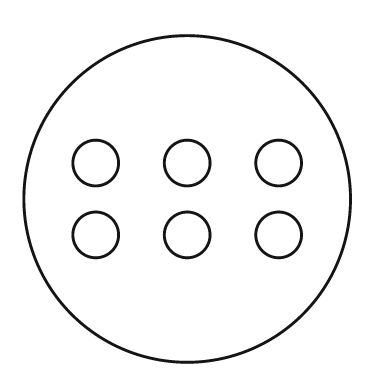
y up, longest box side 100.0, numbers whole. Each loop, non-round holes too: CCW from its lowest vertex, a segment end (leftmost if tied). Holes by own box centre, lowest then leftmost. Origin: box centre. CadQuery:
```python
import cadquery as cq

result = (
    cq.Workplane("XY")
    .moveTo(0.0, 0.0)
    .circle(50.0)
    .moveTo(-28.0, -11.0)
    .circle(7.0)
    .moveTo(0.0, -11.0)
    .circle(7.0)
    .moveTo(28.0, -11.0)
    .circle(7.0)
    .moveTo(-28.0, 11.0)
    .circle(7.0)
    .moveTo(0.0, 11.0)
    .circle(7.0)
    .moveTo(28.0, 11.0)
    .circle(7.0)
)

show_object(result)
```